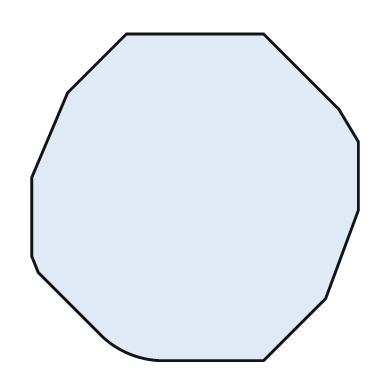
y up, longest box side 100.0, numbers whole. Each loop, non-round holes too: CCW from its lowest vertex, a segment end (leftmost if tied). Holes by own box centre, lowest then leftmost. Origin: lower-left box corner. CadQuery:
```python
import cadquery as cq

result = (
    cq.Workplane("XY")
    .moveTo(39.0, 0.0)
    .lineTo(71.0, 0.0)
    .lineTo(90.0, 19.0)
    .lineTo(100.0, 46.0)
    .lineTo(100.0, 67.0)
    .lineTo(94.0, 77.0)
    .lineTo(71.0, 100.0)
    .lineTo(29.0, 100.0)
    .lineTo(11.0, 82.0)
    .lineTo(0.0, 56.0)
    .lineTo(0.0, 32.0)
    .lineTo(2.0, 27.0)
    .lineTo(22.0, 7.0)
    .threePointArc((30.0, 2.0), (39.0, 0.0))
    .close()
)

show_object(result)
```